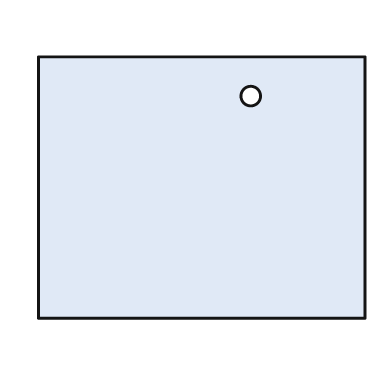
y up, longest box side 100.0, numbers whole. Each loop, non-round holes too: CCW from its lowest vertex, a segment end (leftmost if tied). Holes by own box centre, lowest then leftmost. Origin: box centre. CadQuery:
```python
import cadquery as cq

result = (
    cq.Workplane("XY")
    .moveTo(-50.0, -40.0)
    .lineTo(50.0, -40.0)
    .lineTo(50.0, 40.0)
    .lineTo(-50.0, 40.0)
    .close()
    .moveTo(15.0, 28.0)
    .circle(3.0)
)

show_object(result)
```